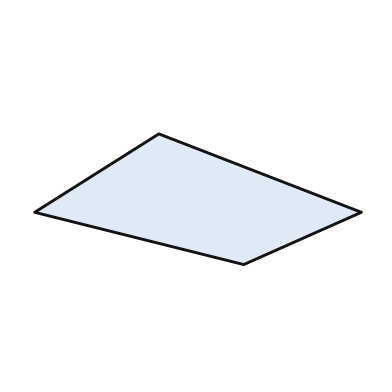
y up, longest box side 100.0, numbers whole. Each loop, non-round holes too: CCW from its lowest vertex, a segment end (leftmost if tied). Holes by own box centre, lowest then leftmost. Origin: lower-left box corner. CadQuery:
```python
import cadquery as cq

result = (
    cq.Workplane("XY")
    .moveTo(64.0, 0.0)
    .lineTo(100.0, 16.0)
    .lineTo(38.0, 40.0)
    .lineTo(0.0, 16.0)
    .close()
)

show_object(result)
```